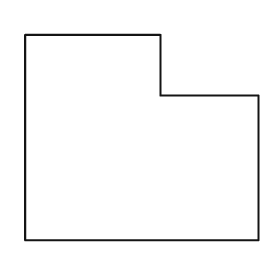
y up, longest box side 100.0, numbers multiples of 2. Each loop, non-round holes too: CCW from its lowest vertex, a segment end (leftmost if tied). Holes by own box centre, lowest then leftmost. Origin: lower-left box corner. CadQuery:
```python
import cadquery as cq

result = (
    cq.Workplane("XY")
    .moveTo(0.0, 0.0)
    .lineTo(100.0, 0.0)
    .lineTo(100.0, 62.0)
    .lineTo(58.0, 62.0)
    .lineTo(58.0, 88.0)
    .lineTo(0.0, 88.0)
    .close()
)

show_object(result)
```